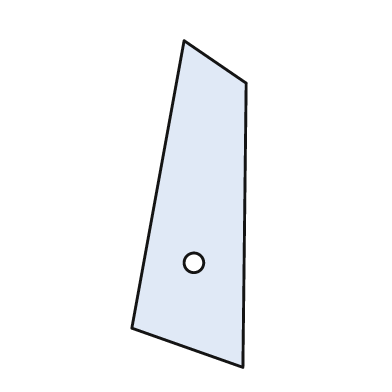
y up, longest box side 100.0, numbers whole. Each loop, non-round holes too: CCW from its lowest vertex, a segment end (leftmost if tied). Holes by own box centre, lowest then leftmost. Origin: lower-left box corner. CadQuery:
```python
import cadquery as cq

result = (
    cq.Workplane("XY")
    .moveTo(34.0, 0.0)
    .lineTo(35.0, 87.0)
    .lineTo(16.0, 100.0)
    .lineTo(0.0, 12.0)
    .close()
    .moveTo(19.0, 32.0)
    .circle(3.0)
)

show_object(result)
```